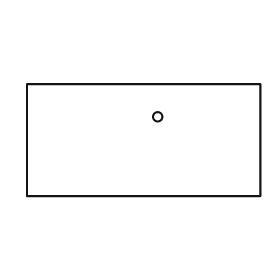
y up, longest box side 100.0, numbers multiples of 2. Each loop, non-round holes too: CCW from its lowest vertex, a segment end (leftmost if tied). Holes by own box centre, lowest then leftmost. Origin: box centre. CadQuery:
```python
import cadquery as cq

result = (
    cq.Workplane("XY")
    .moveTo(-50.0, -24.0)
    .lineTo(50.0, -24.0)
    .lineTo(50.0, 24.0)
    .lineTo(-50.0, 24.0)
    .close()
    .moveTo(6.0, 10.0)
    .circle(2.0)
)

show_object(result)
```